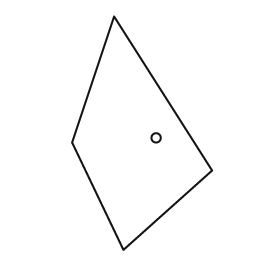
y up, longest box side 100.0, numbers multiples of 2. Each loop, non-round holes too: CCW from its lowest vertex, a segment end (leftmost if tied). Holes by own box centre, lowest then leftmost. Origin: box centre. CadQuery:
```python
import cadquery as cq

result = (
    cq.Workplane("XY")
    .moveTo(-8.0, -50.0)
    .lineTo(30.0, -16.0)
    .lineTo(-12.0, 50.0)
    .lineTo(-30.0, -4.0)
    .close()
    .moveTo(6.0, -2.0)
    .circle(2.0)
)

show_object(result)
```